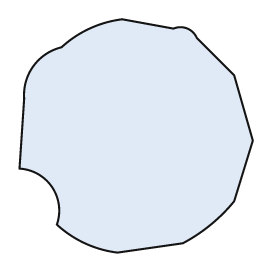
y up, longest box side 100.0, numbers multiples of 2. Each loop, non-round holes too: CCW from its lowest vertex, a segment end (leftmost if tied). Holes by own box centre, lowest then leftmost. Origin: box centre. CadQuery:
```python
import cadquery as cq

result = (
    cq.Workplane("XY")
    .moveTo(-8.0, -50.0)
    .lineTo(20.0, -46.0)
    .threePointArc((32.0, -38.0), (42.0, -28.0))
    .lineTo(50.0, -2.0)
    .lineTo(42.0, 26.0)
    .lineTo(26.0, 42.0)
    .threePointArc((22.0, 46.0), (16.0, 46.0))
    .lineTo(-6.0, 50.0)
    .threePointArc((-20.0, 46.0), (-32.0, 38.0))
    .threePointArc((-44.0, 30.0), (-48.0, 16.0))
    .lineTo(-50.0, -14.0)
    .threePointArc((-36.0, -22.0), (-34.0, -38.0))
    .threePointArc((-22.0, -46.0), (-8.0, -50.0))
    .close()
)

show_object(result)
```